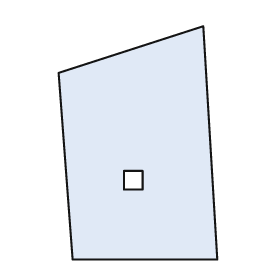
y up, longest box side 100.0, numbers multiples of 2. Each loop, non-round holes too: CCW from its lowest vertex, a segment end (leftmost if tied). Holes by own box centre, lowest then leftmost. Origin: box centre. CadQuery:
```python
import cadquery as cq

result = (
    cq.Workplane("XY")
    .moveTo(-28.0, -50.0)
    .lineTo(34.0, -50.0)
    .lineTo(28.0, 50.0)
    .lineTo(-34.0, 30.0)
    .close()
    .moveTo(-6.0, -20.0)
    .lineTo(2.0, -20.0)
    .lineTo(2.0, -12.0)
    .lineTo(-6.0, -12.0)
    .close()
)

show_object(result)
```